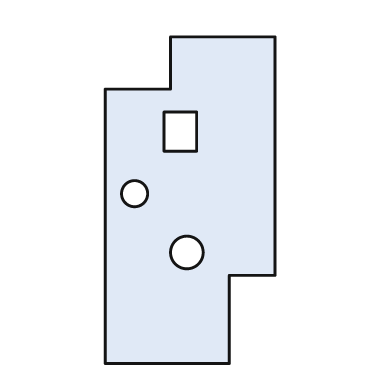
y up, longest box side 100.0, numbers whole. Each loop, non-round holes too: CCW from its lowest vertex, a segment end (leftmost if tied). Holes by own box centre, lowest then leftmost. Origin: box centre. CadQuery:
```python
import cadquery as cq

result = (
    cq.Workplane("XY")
    .moveTo(-26.0, -50.0)
    .lineTo(12.0, -50.0)
    .lineTo(12.0, -23.0)
    .lineTo(26.0, -23.0)
    .lineTo(26.0, 50.0)
    .lineTo(-6.0, 50.0)
    .lineTo(-6.0, 34.0)
    .lineTo(-26.0, 34.0)
    .close()
    .moveTo(-1.0, -16.0)
    .circle(5.0)
    .moveTo(-17.0, 2.0)
    .circle(4.0)
    .moveTo(-8.0, 15.0)
    .lineTo(2.0, 15.0)
    .lineTo(2.0, 27.0)
    .lineTo(-8.0, 27.0)
    .close()
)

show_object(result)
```